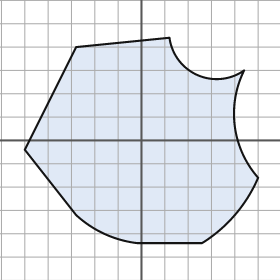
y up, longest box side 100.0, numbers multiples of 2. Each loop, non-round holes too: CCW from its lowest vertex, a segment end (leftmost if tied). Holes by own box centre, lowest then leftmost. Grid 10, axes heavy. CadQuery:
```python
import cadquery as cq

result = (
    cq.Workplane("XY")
    .moveTo(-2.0, -44.0)
    .lineTo(26.0, -44.0)
    .threePointArc((40.0, -32.0), (50.0, -16.0))
    .threePointArc((40.0, 6.0), (44.0, 30.0))
    .threePointArc((24.0, 28.0), (12.0, 44.0))
    .lineTo(-28.0, 40.0)
    .lineTo(-50.0, -4.0)
    .lineTo(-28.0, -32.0)
    .threePointArc((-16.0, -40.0), (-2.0, -44.0))
    .close()
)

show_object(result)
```